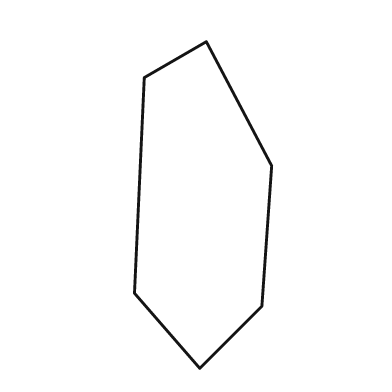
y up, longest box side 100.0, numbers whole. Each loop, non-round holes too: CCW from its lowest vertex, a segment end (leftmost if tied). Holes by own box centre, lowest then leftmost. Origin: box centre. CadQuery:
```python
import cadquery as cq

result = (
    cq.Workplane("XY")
    .moveTo(-1.0, -50.0)
    .lineTo(18.0, -31.0)
    .lineTo(21.0, 12.0)
    .lineTo(1.0, 50.0)
    .lineTo(-18.0, 39.0)
    .lineTo(-21.0, -27.0)
    .close()
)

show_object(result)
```